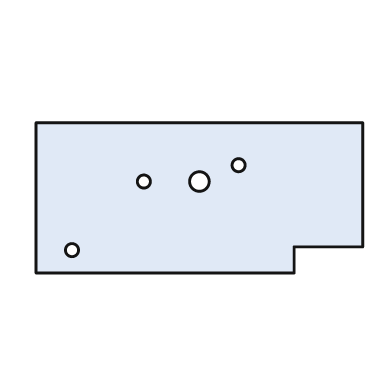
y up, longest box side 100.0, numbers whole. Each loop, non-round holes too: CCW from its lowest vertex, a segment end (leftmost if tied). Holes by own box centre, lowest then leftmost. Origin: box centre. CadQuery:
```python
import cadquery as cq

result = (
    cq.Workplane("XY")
    .moveTo(-50.0, -23.0)
    .lineTo(29.0, -23.0)
    .lineTo(29.0, -15.0)
    .lineTo(50.0, -15.0)
    .lineTo(50.0, 23.0)
    .lineTo(-50.0, 23.0)
    .close()
    .moveTo(-39.0, -16.0)
    .circle(2.0)
    .moveTo(-17.0, 5.0)
    .circle(2.0)
    .moveTo(0.0, 5.0)
    .circle(3.0)
    .moveTo(12.0, 10.0)
    .circle(2.0)
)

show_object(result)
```